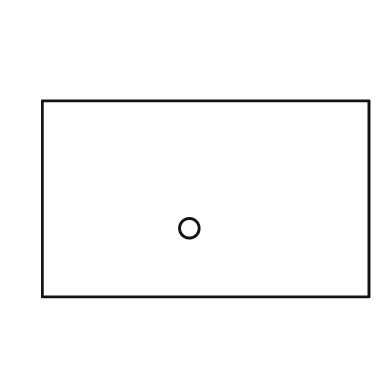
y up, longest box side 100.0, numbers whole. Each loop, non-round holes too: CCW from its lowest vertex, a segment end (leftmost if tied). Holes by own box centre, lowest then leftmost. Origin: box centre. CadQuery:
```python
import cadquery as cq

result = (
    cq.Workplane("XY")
    .moveTo(-50.0, -30.0)
    .lineTo(50.0, -30.0)
    .lineTo(50.0, 30.0)
    .lineTo(-50.0, 30.0)
    .close()
    .moveTo(-5.0, -9.0)
    .circle(3.0)
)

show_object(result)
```